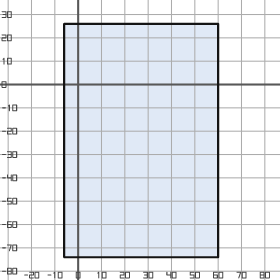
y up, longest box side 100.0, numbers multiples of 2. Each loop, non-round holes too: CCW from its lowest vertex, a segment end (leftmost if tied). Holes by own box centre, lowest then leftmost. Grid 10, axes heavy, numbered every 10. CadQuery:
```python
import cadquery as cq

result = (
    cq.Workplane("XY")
    .moveTo(-6.0, -74.0)
    .lineTo(60.0, -74.0)
    .lineTo(60.0, 26.0)
    .lineTo(-6.0, 26.0)
    .close()
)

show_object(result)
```